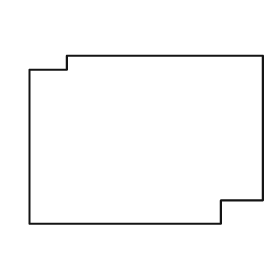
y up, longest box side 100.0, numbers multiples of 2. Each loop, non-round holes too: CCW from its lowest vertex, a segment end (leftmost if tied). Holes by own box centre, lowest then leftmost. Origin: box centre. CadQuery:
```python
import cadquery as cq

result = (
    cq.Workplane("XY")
    .moveTo(-50.0, -36.0)
    .lineTo(32.0, -36.0)
    .lineTo(32.0, -26.0)
    .lineTo(50.0, -26.0)
    .lineTo(50.0, 36.0)
    .lineTo(-34.0, 36.0)
    .lineTo(-34.0, 30.0)
    .lineTo(-50.0, 30.0)
    .close()
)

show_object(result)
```